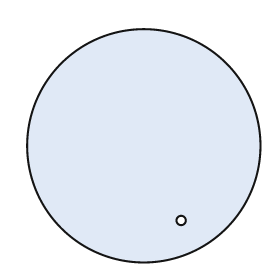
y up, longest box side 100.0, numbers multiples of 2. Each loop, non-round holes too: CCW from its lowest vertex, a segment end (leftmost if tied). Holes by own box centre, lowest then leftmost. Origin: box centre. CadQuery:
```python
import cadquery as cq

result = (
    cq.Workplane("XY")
    .moveTo(0.0, 0.0)
    .circle(50.0)
    .moveTo(16.0, -32.0)
    .circle(2.0)
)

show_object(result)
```